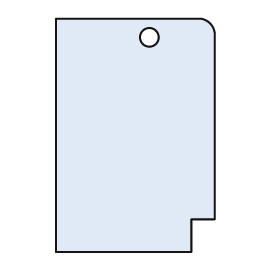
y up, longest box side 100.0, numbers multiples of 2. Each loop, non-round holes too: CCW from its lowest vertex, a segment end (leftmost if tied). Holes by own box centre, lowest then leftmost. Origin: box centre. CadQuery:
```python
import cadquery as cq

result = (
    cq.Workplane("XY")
    .moveTo(-34.0, -50.0)
    .lineTo(24.0, -50.0)
    .lineTo(24.0, -36.0)
    .lineTo(34.0, -36.0)
    .lineTo(34.0, 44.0)
    .threePointArc((32.0, 48.0), (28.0, 50.0))
    .lineTo(-34.0, 50.0)
    .close()
    .moveTo(6.0, 42.0)
    .circle(4.0)
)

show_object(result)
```